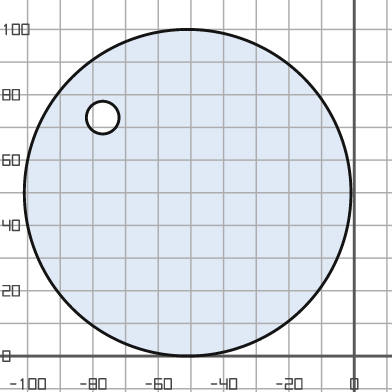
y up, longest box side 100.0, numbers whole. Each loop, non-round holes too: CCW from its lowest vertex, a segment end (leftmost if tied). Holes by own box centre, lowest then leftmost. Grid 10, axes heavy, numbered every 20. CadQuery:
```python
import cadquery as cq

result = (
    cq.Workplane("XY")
    .moveTo(-51.0, 50.0)
    .circle(50.0)
    .moveTo(-77.0, 73.0)
    .circle(5.0)
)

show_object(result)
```